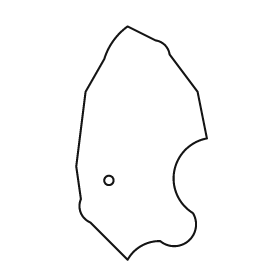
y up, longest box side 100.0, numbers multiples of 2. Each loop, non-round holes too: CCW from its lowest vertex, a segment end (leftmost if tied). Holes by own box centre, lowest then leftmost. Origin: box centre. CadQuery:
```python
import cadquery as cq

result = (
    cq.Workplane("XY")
    .moveTo(-6.0, -50.0)
    .threePointArc((0.0, -44.0), (8.0, -42.0))
    .threePointArc((20.0, -42.0), (22.0, -30.0))
    .threePointArc((14.0, -12.0), (28.0, 2.0))
    .lineTo(24.0, 22.0)
    .lineTo(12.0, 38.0)
    .threePointArc((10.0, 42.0), (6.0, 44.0))
    .lineTo(-6.0, 50.0)
    .threePointArc((-12.0, 44.0), (-16.0, 36.0))
    .lineTo(-24.0, 22.0)
    .lineTo(-28.0, -10.0)
    .lineTo(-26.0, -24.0)
    .threePointArc((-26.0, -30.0), (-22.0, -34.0))
    .close()
    .moveTo(-14.0, -16.0)
    .circle(2.0)
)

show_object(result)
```